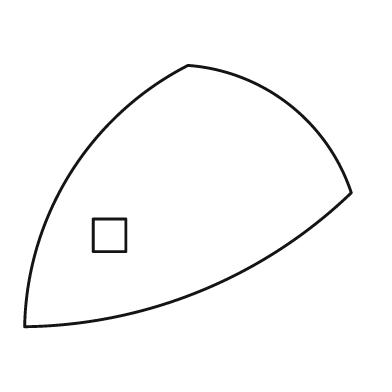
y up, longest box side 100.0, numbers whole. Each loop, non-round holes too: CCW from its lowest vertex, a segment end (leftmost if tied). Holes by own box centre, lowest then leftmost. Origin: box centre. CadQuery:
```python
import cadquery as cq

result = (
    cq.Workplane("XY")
    .moveTo(-50.0, -40.0)
    .threePointArc((4.0, -29.0), (50.0, 1.0))
    .threePointArc((31.0, 28.0), (0.0, 40.0))
    .threePointArc((-36.0, 7.0), (-50.0, -40.0))
    .close()
    .moveTo(-29.0, -17.0)
    .lineTo(-19.0, -17.0)
    .lineTo(-19.0, -7.0)
    .lineTo(-29.0, -7.0)
    .close()
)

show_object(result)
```